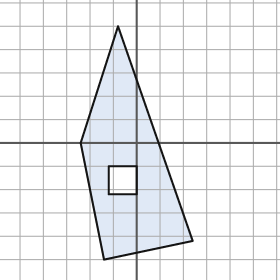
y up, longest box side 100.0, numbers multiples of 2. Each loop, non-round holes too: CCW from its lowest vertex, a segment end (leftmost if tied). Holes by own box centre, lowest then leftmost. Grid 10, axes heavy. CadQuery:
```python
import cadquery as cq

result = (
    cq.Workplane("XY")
    .moveTo(-14.0, -50.0)
    .lineTo(24.0, -42.0)
    .lineTo(-8.0, 50.0)
    .lineTo(-24.0, 0.0)
    .close()
    .moveTo(-12.0, -22.0)
    .lineTo(0.0, -22.0)
    .lineTo(0.0, -10.0)
    .lineTo(-12.0, -10.0)
    .close()
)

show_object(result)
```